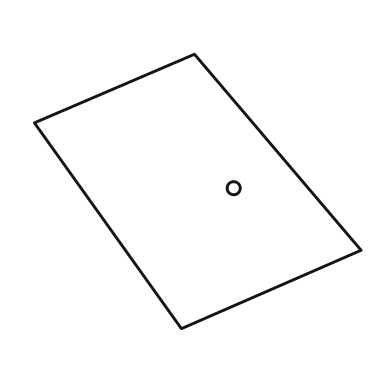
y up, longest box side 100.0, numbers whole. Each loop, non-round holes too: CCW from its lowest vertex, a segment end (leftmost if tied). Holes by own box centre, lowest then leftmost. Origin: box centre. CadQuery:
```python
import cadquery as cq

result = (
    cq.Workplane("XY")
    .moveTo(-5.0, -42.0)
    .lineTo(50.0, -18.0)
    .lineTo(-1.0, 42.0)
    .lineTo(-50.0, 21.0)
    .close()
    .moveTo(11.0, 1.0)
    .circle(2.0)
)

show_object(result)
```